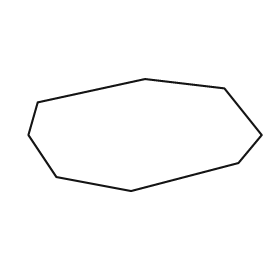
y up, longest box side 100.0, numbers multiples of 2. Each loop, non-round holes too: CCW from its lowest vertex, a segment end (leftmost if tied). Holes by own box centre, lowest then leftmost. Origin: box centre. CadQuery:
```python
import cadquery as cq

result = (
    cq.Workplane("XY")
    .moveTo(-6.0, -24.0)
    .lineTo(40.0, -12.0)
    .lineTo(50.0, 0.0)
    .lineTo(34.0, 20.0)
    .lineTo(0.0, 24.0)
    .lineTo(-46.0, 14.0)
    .lineTo(-50.0, 0.0)
    .lineTo(-38.0, -18.0)
    .close()
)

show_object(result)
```